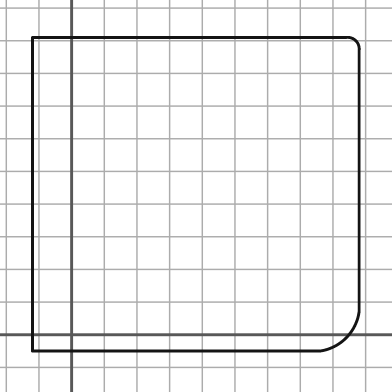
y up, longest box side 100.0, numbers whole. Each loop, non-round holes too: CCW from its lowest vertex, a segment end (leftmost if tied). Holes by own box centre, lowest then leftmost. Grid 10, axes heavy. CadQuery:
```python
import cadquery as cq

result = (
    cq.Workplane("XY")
    .moveTo(-12.0, -5.0)
    .lineTo(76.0, -5.0)
    .threePointArc((84.0, -1.0), (88.0, 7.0))
    .lineTo(88.0, 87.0)
    .threePointArc((87.0, 90.0), (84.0, 91.0))
    .lineTo(-12.0, 91.0)
    .close()
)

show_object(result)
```